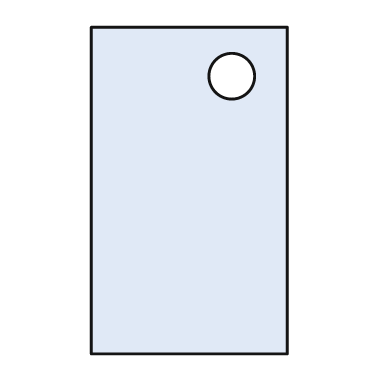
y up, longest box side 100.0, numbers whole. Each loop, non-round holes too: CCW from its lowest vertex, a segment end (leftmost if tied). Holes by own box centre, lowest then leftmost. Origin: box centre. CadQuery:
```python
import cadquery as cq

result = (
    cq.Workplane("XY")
    .moveTo(-30.0, -50.0)
    .lineTo(30.0, -50.0)
    .lineTo(30.0, 50.0)
    .lineTo(-30.0, 50.0)
    .close()
    .moveTo(13.0, 35.0)
    .circle(7.0)
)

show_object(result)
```